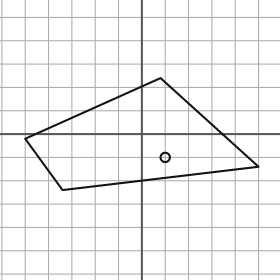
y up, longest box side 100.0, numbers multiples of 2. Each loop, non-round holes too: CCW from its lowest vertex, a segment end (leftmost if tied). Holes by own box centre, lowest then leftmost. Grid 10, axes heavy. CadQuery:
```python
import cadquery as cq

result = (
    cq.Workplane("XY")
    .moveTo(-34.0, -24.0)
    .lineTo(50.0, -14.0)
    .lineTo(8.0, 24.0)
    .lineTo(-50.0, -2.0)
    .close()
    .moveTo(10.0, -10.0)
    .circle(2.0)
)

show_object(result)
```